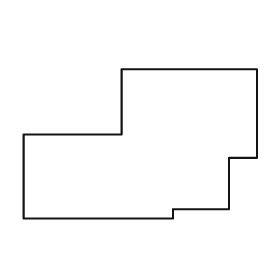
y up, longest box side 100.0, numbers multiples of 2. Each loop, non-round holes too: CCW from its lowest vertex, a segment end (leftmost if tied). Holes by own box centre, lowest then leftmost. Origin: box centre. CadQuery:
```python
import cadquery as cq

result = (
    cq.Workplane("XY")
    .moveTo(-50.0, -32.0)
    .lineTo(14.0, -32.0)
    .lineTo(14.0, -28.0)
    .lineTo(38.0, -28.0)
    .lineTo(38.0, -6.0)
    .lineTo(50.0, -6.0)
    .lineTo(50.0, 32.0)
    .lineTo(-8.0, 32.0)
    .lineTo(-8.0, 4.0)
    .lineTo(-50.0, 4.0)
    .close()
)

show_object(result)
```